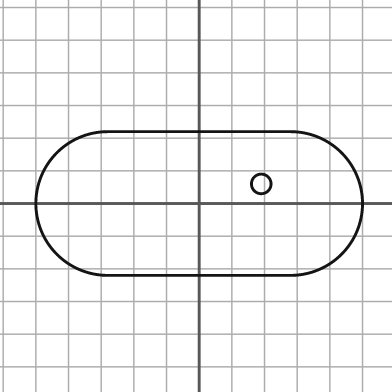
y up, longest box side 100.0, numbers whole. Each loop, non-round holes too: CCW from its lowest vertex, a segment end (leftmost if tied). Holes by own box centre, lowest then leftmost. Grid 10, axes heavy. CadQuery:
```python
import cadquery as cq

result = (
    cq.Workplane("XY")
    .moveTo(-28.0, -22.0)
    .lineTo(28.0, -22.0)
    .threePointArc((50.0, 0.0), (28.0, 22.0))
    .lineTo(-28.0, 22.0)
    .threePointArc((-50.0, 0.0), (-28.0, -22.0))
    .close()
    .moveTo(19.0, 6.0)
    .circle(3.0)
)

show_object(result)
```